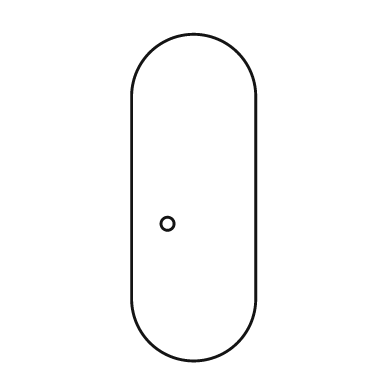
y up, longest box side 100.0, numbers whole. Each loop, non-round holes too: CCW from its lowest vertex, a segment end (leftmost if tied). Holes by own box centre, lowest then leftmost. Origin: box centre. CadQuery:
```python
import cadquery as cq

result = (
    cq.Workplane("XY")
    .moveTo(-19.0, -31.0)
    .threePointArc((0.0, -50.0), (19.0, -31.0))
    .lineTo(19.0, 31.0)
    .threePointArc((0.0, 50.0), (-19.0, 31.0))
    .close()
    .moveTo(-8.0, -8.0)
    .circle(2.0)
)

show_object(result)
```